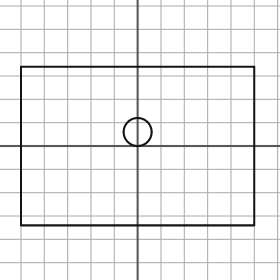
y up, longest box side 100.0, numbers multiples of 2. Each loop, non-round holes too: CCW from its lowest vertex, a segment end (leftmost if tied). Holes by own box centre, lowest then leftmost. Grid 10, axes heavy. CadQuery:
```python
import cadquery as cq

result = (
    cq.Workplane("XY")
    .moveTo(-50.0, -34.0)
    .lineTo(50.0, -34.0)
    .lineTo(50.0, 34.0)
    .lineTo(-50.0, 34.0)
    .close()
    .moveTo(0.0, 6.0)
    .circle(6.0)
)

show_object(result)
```